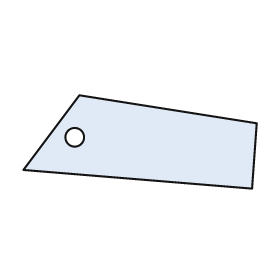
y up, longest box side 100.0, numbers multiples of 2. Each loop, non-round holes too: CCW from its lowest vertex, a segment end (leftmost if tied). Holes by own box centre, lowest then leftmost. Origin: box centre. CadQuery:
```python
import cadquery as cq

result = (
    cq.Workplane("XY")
    .moveTo(48.0, -20.0)
    .lineTo(50.0, 8.0)
    .lineTo(-26.0, 20.0)
    .lineTo(-50.0, -12.0)
    .close()
    .moveTo(-28.0, 2.0)
    .circle(4.0)
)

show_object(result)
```